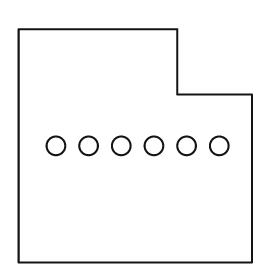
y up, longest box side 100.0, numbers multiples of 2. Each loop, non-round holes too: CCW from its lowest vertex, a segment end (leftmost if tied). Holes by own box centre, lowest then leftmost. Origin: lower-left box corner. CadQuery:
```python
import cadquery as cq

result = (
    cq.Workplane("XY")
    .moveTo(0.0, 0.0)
    .lineTo(100.0, 0.0)
    .lineTo(100.0, 72.0)
    .lineTo(68.0, 72.0)
    .lineTo(68.0, 100.0)
    .lineTo(0.0, 100.0)
    .close()
    .moveTo(16.0, 50.0)
    .circle(4.0)
    .moveTo(30.0, 50.0)
    .circle(4.0)
    .moveTo(44.0, 50.0)
    .circle(4.0)
    .moveTo(58.0, 50.0)
    .circle(4.0)
    .moveTo(72.0, 50.0)
    .circle(4.0)
    .moveTo(86.0, 50.0)
    .circle(4.0)
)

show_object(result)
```